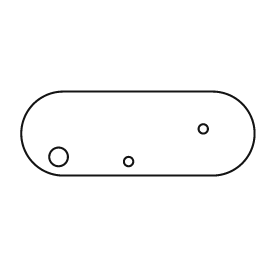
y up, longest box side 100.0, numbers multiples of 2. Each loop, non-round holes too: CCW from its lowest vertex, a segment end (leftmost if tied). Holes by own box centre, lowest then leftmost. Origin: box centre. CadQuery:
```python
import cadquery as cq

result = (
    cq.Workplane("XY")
    .moveTo(-32.0, -18.0)
    .lineTo(32.0, -18.0)
    .threePointArc((50.0, 0.0), (32.0, 18.0))
    .lineTo(-32.0, 18.0)
    .threePointArc((-50.0, 0.0), (-32.0, -18.0))
    .close()
    .moveTo(-4.0, -12.0)
    .circle(2.0)
    .moveTo(-34.0, -10.0)
    .circle(4.0)
    .moveTo(28.0, 2.0)
    .circle(2.0)
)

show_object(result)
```